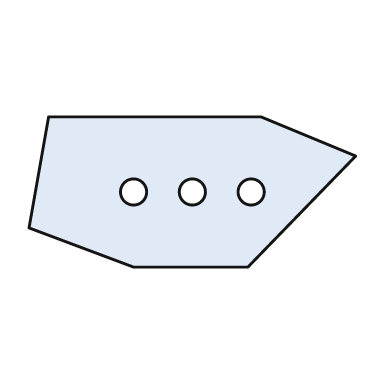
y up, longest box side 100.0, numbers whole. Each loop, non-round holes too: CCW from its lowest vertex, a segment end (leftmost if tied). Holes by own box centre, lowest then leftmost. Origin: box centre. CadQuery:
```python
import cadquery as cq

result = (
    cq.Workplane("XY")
    .moveTo(-18.0, -23.0)
    .lineTo(17.0, -23.0)
    .lineTo(50.0, 11.0)
    .lineTo(21.0, 23.0)
    .lineTo(-44.0, 23.0)
    .lineTo(-50.0, -11.0)
    .close()
    .moveTo(-18.0, 0.0)
    .circle(4.0)
    .moveTo(0.0, 0.0)
    .circle(4.0)
    .moveTo(18.0, 0.0)
    .circle(4.0)
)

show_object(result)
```